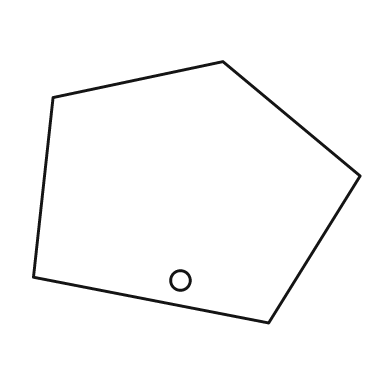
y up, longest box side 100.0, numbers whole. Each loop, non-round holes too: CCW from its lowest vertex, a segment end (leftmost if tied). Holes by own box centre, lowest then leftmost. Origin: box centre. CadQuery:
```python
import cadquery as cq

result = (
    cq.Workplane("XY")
    .moveTo(22.0, -40.0)
    .lineTo(50.0, 5.0)
    .lineTo(8.0, 40.0)
    .lineTo(-44.0, 29.0)
    .lineTo(-50.0, -26.0)
    .close()
    .moveTo(-5.0, -27.0)
    .circle(3.0)
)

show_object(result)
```